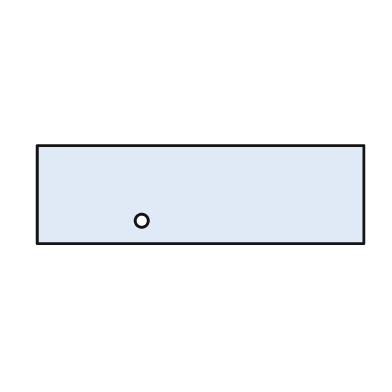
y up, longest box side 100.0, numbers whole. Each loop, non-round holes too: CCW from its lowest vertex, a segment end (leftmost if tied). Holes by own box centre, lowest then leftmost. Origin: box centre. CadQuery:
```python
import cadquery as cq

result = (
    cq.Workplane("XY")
    .moveTo(-50.0, -15.0)
    .lineTo(50.0, -15.0)
    .lineTo(50.0, 15.0)
    .lineTo(-50.0, 15.0)
    .close()
    .moveTo(-18.0, -8.0)
    .circle(2.0)
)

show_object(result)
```